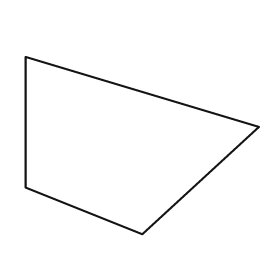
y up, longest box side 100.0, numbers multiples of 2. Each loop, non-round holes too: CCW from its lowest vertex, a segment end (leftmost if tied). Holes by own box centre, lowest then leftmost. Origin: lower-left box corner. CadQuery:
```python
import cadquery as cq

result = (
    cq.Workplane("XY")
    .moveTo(50.0, 0.0)
    .lineTo(100.0, 46.0)
    .lineTo(0.0, 76.0)
    .lineTo(0.0, 20.0)
    .close()
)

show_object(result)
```